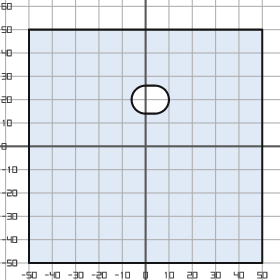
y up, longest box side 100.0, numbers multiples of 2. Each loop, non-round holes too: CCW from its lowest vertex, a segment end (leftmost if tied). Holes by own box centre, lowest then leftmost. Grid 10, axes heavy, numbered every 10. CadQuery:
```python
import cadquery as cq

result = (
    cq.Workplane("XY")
    .moveTo(-50.0, -50.0)
    .lineTo(50.0, -50.0)
    .lineTo(50.0, 50.0)
    .lineTo(-50.0, 50.0)
    .close()
    .moveTo(0.0, 14.0)
    .lineTo(4.0, 14.0)
    .threePointArc((10.0, 20.0), (4.0, 26.0))
    .lineTo(0.0, 26.0)
    .threePointArc((-6.0, 20.0), (0.0, 14.0))
    .close()
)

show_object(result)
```